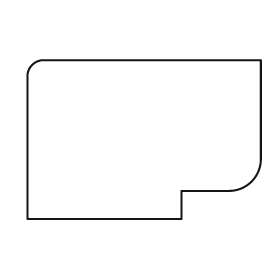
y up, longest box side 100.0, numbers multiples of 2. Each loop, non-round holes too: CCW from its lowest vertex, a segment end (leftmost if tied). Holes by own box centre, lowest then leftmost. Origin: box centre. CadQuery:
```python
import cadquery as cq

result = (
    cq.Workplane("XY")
    .moveTo(-50.0, -34.0)
    .lineTo(16.0, -34.0)
    .lineTo(16.0, -22.0)
    .lineTo(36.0, -22.0)
    .threePointArc((46.0, -18.0), (50.0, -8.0))
    .lineTo(50.0, 34.0)
    .lineTo(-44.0, 34.0)
    .threePointArc((-48.0, 32.0), (-50.0, 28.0))
    .close()
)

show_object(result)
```